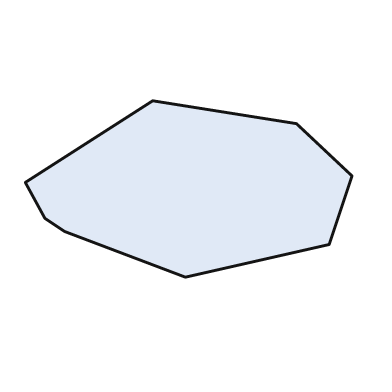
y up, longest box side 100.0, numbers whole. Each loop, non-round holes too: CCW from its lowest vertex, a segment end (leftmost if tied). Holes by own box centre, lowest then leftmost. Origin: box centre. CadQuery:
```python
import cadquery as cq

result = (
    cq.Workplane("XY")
    .moveTo(-1.0, -27.0)
    .lineTo(43.0, -17.0)
    .lineTo(50.0, 4.0)
    .lineTo(33.0, 20.0)
    .lineTo(-11.0, 27.0)
    .lineTo(-50.0, 2.0)
    .lineTo(-44.0, -9.0)
    .lineTo(-38.0, -13.0)
    .close()
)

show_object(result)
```